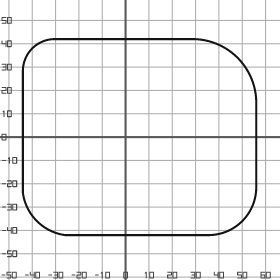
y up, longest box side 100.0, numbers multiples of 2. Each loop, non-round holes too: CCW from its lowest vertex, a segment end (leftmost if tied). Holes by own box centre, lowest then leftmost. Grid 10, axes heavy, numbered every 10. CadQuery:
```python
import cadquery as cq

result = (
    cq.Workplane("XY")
    .moveTo(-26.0, -42.0)
    .lineTo(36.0, -42.0)
    .threePointArc((50.0, -36.0), (56.0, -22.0))
    .lineTo(56.0, 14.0)
    .threePointArc((48.0, 34.0), (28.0, 42.0))
    .lineTo(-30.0, 42.0)
    .threePointArc((-40.0, 38.0), (-44.0, 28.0))
    .lineTo(-44.0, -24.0)
    .threePointArc((-38.0, -36.0), (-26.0, -42.0))
    .close()
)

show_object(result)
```